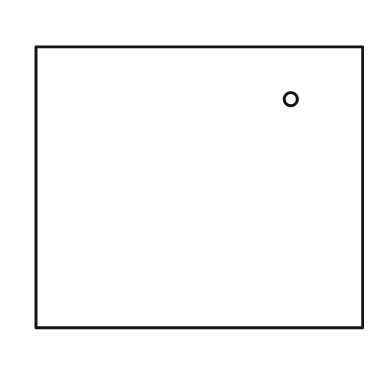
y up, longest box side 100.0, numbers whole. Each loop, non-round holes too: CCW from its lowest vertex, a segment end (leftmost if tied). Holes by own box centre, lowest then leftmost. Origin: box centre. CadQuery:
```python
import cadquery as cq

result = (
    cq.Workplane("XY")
    .moveTo(-50.0, -43.0)
    .lineTo(50.0, -43.0)
    .lineTo(50.0, 43.0)
    .lineTo(-50.0, 43.0)
    .close()
    .moveTo(28.0, 27.0)
    .circle(2.0)
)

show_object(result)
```